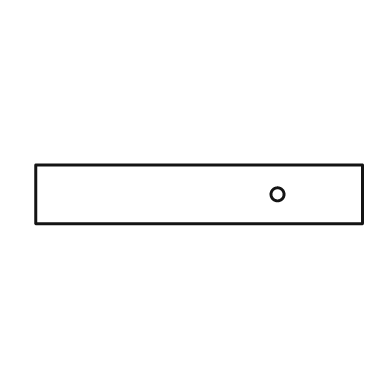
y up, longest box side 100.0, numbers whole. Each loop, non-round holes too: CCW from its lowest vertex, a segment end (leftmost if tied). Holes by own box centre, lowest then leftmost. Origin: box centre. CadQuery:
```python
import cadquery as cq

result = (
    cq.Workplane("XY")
    .moveTo(-50.0, -9.0)
    .lineTo(50.0, -9.0)
    .lineTo(50.0, 9.0)
    .lineTo(-50.0, 9.0)
    .close()
    .moveTo(24.0, 0.0)
    .circle(2.0)
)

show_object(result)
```